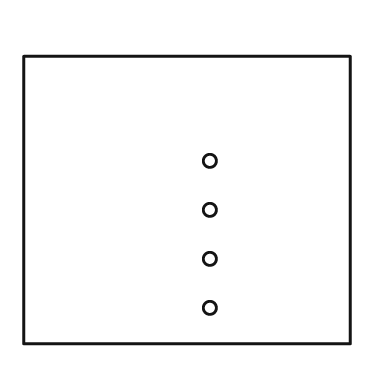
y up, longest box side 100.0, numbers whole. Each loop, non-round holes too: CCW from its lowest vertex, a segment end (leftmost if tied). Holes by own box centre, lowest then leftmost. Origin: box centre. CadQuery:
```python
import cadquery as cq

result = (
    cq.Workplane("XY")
    .moveTo(-50.0, -44.0)
    .lineTo(50.0, -44.0)
    .lineTo(50.0, 44.0)
    .lineTo(-50.0, 44.0)
    .close()
    .moveTo(7.0, -33.0)
    .circle(2.0)
    .moveTo(7.0, -18.0)
    .circle(2.0)
    .moveTo(7.0, -3.0)
    .circle(2.0)
    .moveTo(7.0, 12.0)
    .circle(2.0)
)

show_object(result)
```